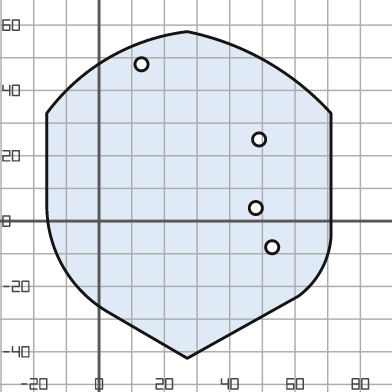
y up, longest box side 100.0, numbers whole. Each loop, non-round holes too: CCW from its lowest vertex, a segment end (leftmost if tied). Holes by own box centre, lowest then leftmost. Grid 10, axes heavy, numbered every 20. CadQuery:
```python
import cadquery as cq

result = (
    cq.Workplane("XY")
    .moveTo(27.0, -42.0)
    .lineTo(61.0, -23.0)
    .threePointArc((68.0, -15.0), (71.0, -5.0))
    .lineTo(71.0, 33.0)
    .threePointArc((51.0, 49.0), (27.0, 58.0))
    .threePointArc((3.0, 50.0), (-16.0, 33.0))
    .lineTo(-16.0, 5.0)
    .threePointArc((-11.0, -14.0), (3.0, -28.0))
    .close()
    .moveTo(53.0, -8.0)
    .circle(2.0)
    .moveTo(48.0, 4.0)
    .circle(2.0)
    .moveTo(49.0, 25.0)
    .circle(2.0)
    .moveTo(13.0, 48.0)
    .circle(2.0)
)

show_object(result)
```